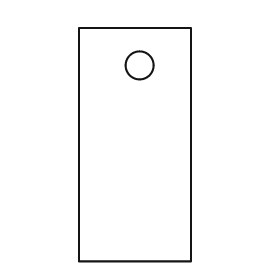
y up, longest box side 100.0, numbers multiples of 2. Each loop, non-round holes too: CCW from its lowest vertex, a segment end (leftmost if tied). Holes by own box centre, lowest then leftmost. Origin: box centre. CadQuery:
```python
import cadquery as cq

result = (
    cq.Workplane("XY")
    .moveTo(-24.0, -50.0)
    .lineTo(24.0, -50.0)
    .lineTo(24.0, 50.0)
    .lineTo(-24.0, 50.0)
    .close()
    .moveTo(2.0, 34.0)
    .circle(6.0)
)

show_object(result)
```